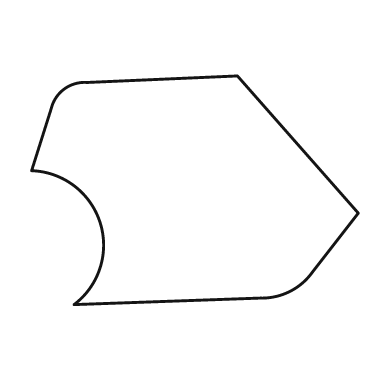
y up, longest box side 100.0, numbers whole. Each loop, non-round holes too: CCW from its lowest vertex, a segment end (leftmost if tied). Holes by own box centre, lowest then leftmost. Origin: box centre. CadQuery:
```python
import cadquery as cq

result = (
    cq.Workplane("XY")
    .moveTo(-37.0, -35.0)
    .lineTo(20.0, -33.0)
    .threePointArc((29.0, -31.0), (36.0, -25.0))
    .lineTo(50.0, -7.0)
    .lineTo(13.0, 35.0)
    .lineTo(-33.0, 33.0)
    .threePointArc((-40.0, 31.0), (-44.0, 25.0))
    .lineTo(-50.0, 6.0)
    .threePointArc((-29.0, -10.0), (-37.0, -35.0))
    .close()
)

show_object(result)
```